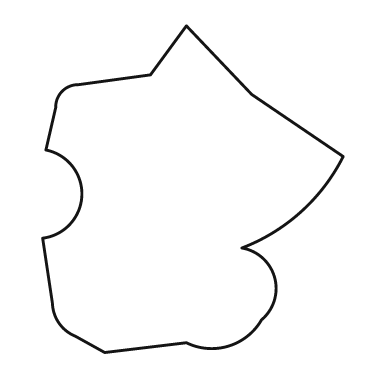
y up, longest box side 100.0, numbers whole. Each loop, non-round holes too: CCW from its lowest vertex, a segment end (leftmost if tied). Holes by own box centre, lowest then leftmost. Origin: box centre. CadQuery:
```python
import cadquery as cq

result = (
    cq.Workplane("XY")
    .moveTo(-27.0, -50.0)
    .lineTo(-2.0, -47.0)
    .threePointArc((11.0, -48.0), (21.0, -40.0))
    .threePointArc((25.0, -27.0), (15.0, -18.0))
    .threePointArc((33.0, -7.0), (46.0, 10.0))
    .lineTo(18.0, 29.0)
    .lineTo(-2.0, 50.0)
    .lineTo(-13.0, 35.0)
    .lineTo(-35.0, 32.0)
    .threePointArc((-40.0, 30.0), (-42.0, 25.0))
    .lineTo(-45.0, 12.0)
    .threePointArc((-34.0, -2.0), (-46.0, -15.0))
    .lineTo(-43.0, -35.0)
    .threePointArc((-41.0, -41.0), (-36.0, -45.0))
    .close()
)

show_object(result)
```